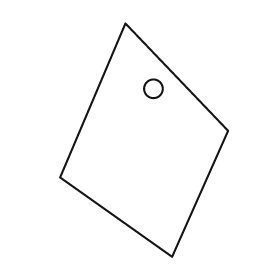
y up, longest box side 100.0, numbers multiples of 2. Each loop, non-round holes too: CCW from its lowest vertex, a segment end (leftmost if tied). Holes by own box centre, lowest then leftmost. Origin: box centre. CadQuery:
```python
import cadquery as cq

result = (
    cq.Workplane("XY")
    .moveTo(12.0, -50.0)
    .lineTo(36.0, 4.0)
    .lineTo(-8.0, 50.0)
    .lineTo(-36.0, -16.0)
    .close()
    .moveTo(4.0, 22.0)
    .circle(4.0)
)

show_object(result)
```